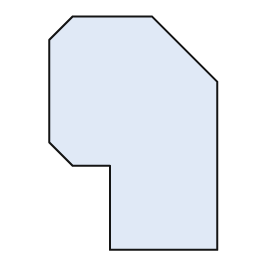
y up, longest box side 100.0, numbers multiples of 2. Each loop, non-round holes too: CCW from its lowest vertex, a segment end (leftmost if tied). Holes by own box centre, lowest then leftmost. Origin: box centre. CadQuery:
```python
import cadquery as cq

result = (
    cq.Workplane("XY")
    .moveTo(-10.0, -50.0)
    .lineTo(36.0, -50.0)
    .lineTo(36.0, 22.0)
    .lineTo(8.0, 50.0)
    .lineTo(-26.0, 50.0)
    .lineTo(-36.0, 40.0)
    .lineTo(-36.0, -4.0)
    .lineTo(-26.0, -14.0)
    .lineTo(-10.0, -14.0)
    .close()
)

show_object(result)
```